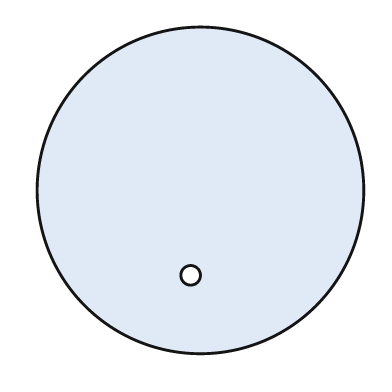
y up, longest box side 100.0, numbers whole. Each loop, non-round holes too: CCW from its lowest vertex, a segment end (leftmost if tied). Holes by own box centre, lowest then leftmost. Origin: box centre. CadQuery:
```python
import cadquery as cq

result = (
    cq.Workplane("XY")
    .moveTo(0.0, 0.0)
    .circle(50.0)
    .moveTo(-3.0, -26.0)
    .circle(3.0)
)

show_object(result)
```